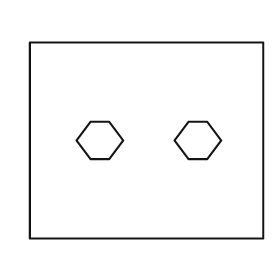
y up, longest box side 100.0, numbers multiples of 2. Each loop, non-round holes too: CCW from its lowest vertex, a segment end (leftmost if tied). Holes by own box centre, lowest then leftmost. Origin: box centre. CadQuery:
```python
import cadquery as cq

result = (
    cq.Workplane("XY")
    .moveTo(-50.0, -42.0)
    .lineTo(50.0, -42.0)
    .lineTo(50.0, 42.0)
    .lineTo(-50.0, 42.0)
    .close()
    .moveTo(-24.0, -8.0)
    .lineTo(-16.0, -8.0)
    .lineTo(-10.0, 0.0)
    .lineTo(-16.0, 8.0)
    .lineTo(-24.0, 8.0)
    .lineTo(-30.0, 0.0)
    .close()
    .moveTo(18.0, -8.0)
    .lineTo(26.0, -8.0)
    .lineTo(32.0, 0.0)
    .lineTo(26.0, 8.0)
    .lineTo(18.0, 8.0)
    .lineTo(12.0, 0.0)
    .close()
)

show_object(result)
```